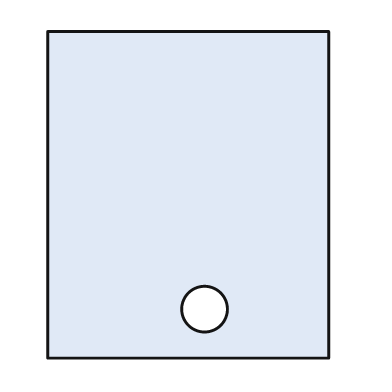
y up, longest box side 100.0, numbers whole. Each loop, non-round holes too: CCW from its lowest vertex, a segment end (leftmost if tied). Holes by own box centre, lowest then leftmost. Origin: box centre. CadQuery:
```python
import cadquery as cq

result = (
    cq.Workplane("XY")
    .moveTo(-43.0, -50.0)
    .lineTo(43.0, -50.0)
    .lineTo(43.0, 50.0)
    .lineTo(-43.0, 50.0)
    .close()
    .moveTo(5.0, -35.0)
    .circle(7.0)
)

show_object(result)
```